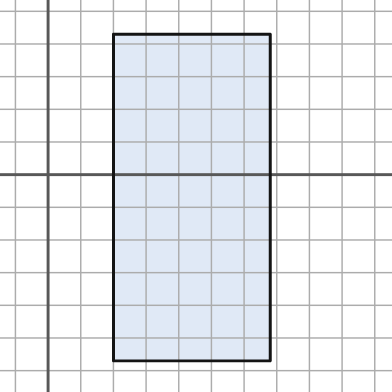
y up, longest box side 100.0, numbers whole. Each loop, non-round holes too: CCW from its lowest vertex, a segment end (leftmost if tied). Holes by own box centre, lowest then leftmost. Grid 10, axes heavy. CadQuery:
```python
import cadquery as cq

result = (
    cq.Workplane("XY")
    .moveTo(20.0, -57.0)
    .lineTo(68.0, -57.0)
    .lineTo(68.0, 43.0)
    .lineTo(20.0, 43.0)
    .close()
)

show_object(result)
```